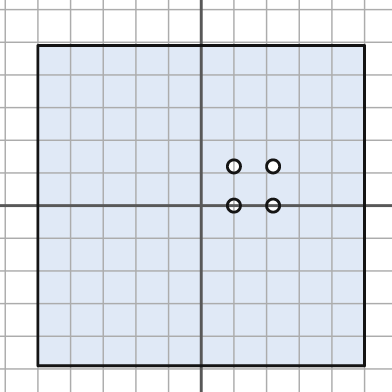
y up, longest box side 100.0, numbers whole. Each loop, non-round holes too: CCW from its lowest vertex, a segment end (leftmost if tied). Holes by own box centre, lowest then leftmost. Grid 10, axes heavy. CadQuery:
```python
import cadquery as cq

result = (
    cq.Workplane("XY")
    .moveTo(-50.0, -49.0)
    .lineTo(50.0, -49.0)
    .lineTo(50.0, 49.0)
    .lineTo(-50.0, 49.0)
    .close()
    .moveTo(10.0, 0.0)
    .circle(2.0)
    .moveTo(22.0, 0.0)
    .circle(2.0)
    .moveTo(10.0, 12.0)
    .circle(2.0)
    .moveTo(22.0, 12.0)
    .circle(2.0)
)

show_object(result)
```